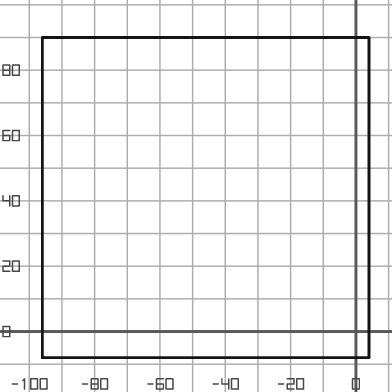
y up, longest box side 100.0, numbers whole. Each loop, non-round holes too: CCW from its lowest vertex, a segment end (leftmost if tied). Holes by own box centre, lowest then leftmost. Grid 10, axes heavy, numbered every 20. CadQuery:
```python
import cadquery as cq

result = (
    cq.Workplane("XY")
    .moveTo(-96.0, -8.0)
    .lineTo(4.0, -8.0)
    .lineTo(4.0, 90.0)
    .lineTo(-96.0, 90.0)
    .close()
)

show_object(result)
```